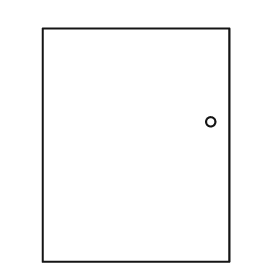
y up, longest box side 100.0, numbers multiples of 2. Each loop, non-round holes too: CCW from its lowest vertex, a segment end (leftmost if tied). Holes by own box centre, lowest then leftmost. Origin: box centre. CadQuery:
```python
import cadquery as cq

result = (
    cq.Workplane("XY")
    .moveTo(-40.0, -50.0)
    .lineTo(40.0, -50.0)
    .lineTo(40.0, 50.0)
    .lineTo(-40.0, 50.0)
    .close()
    .moveTo(32.0, 10.0)
    .circle(2.0)
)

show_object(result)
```